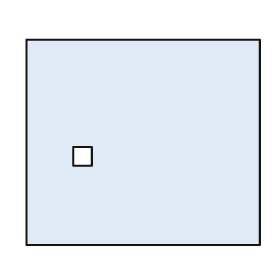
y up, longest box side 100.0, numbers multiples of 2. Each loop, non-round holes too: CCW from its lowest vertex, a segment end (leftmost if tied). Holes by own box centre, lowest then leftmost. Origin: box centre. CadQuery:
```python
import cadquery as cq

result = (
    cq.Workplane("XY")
    .moveTo(-50.0, -44.0)
    .lineTo(50.0, -44.0)
    .lineTo(50.0, 44.0)
    .lineTo(-50.0, 44.0)
    .close()
    .moveTo(-30.0, -10.0)
    .lineTo(-22.0, -10.0)
    .lineTo(-22.0, -2.0)
    .lineTo(-30.0, -2.0)
    .close()
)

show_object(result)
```